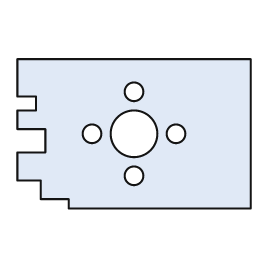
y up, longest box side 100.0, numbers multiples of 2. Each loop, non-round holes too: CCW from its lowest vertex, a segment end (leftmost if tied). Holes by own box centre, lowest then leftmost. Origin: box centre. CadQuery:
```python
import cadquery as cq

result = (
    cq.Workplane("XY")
    .moveTo(-28.0, -32.0)
    .lineTo(50.0, -32.0)
    .lineTo(50.0, 32.0)
    .lineTo(-50.0, 32.0)
    .lineTo(-50.0, 16.0)
    .lineTo(-42.0, 16.0)
    .lineTo(-42.0, 10.0)
    .lineTo(-50.0, 10.0)
    .lineTo(-50.0, 2.0)
    .lineTo(-38.0, 2.0)
    .lineTo(-38.0, -8.0)
    .lineTo(-50.0, -8.0)
    .lineTo(-50.0, -20.0)
    .lineTo(-40.0, -20.0)
    .lineTo(-40.0, -28.0)
    .lineTo(-28.0, -28.0)
    .close()
    .moveTo(0.0, -18.0)
    .circle(4.0)
    .moveTo(-18.0, 0.0)
    .circle(4.0)
    .moveTo(0.0, 0.0)
    .circle(10.0)
    .moveTo(18.0, 0.0)
    .circle(4.0)
    .moveTo(0.0, 18.0)
    .circle(4.0)
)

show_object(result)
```